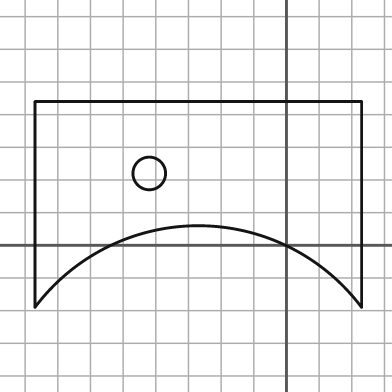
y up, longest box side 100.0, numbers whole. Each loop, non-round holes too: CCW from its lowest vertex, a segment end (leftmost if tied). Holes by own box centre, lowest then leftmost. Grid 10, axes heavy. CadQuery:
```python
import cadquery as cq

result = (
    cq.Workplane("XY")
    .moveTo(-77.0, -19.0)
    .threePointArc((-27.0, 6.0), (23.0, -19.0))
    .lineTo(23.0, 44.0)
    .lineTo(-77.0, 44.0)
    .close()
    .moveTo(-42.0, 22.0)
    .circle(5.0)
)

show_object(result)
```